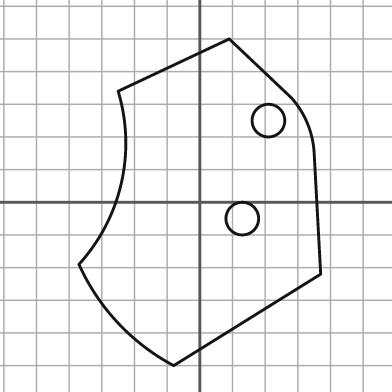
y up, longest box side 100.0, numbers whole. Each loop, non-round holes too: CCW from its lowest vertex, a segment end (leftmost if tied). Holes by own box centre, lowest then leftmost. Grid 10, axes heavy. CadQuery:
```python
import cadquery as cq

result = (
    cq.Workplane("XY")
    .moveTo(-8.0, -50.0)
    .lineTo(37.0, -22.0)
    .lineTo(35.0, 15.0)
    .threePointArc((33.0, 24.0), (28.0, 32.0))
    .lineTo(9.0, 50.0)
    .lineTo(-25.0, 34.0)
    .threePointArc((-24.0, 6.0), (-37.0, -19.0))
    .threePointArc((-25.0, -37.0), (-8.0, -50.0))
    .close()
    .moveTo(13.0, -5.0)
    .circle(5.0)
    .moveTo(21.0, 25.0)
    .circle(5.0)
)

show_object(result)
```